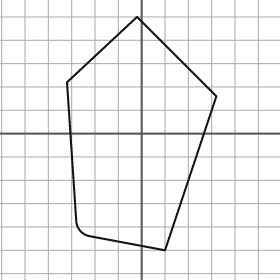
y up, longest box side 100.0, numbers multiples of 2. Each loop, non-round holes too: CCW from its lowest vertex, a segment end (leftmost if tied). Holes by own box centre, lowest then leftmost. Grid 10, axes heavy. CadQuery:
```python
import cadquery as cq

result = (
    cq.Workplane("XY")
    .moveTo(10.0, -50.0)
    .lineTo(32.0, 16.0)
    .lineTo(-2.0, 50.0)
    .lineTo(-32.0, 22.0)
    .lineTo(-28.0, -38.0)
    .threePointArc((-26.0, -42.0), (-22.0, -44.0))
    .close()
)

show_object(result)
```